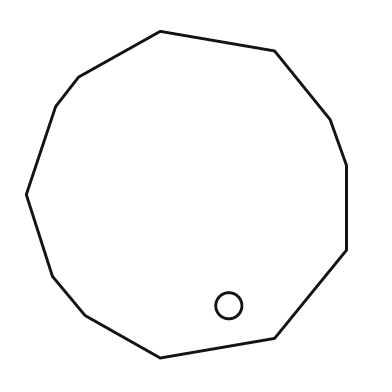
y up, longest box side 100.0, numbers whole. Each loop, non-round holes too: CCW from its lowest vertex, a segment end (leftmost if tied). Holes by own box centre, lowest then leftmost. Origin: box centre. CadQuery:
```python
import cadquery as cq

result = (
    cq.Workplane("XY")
    .moveTo(-8.0, -50.0)
    .lineTo(27.0, -44.0)
    .lineTo(49.0, -17.0)
    .lineTo(49.0, 9.0)
    .lineTo(44.0, 23.0)
    .lineTo(27.0, 44.0)
    .lineTo(-8.0, 50.0)
    .lineTo(-33.0, 36.0)
    .lineTo(-40.0, 27.0)
    .lineTo(-49.0, 0.0)
    .lineTo(-41.0, -25.0)
    .lineTo(-31.0, -37.0)
    .close()
    .moveTo(13.0, -34.0)
    .circle(4.0)
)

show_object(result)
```